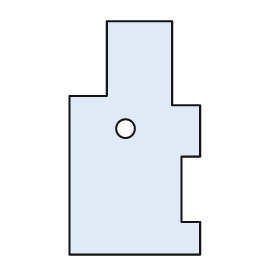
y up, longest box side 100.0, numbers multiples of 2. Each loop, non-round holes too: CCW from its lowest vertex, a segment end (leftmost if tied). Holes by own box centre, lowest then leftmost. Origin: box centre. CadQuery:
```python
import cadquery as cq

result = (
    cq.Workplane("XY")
    .moveTo(-28.0, -50.0)
    .lineTo(28.0, -50.0)
    .lineTo(28.0, -36.0)
    .lineTo(20.0, -36.0)
    .lineTo(20.0, -8.0)
    .lineTo(28.0, -8.0)
    .lineTo(28.0, 14.0)
    .lineTo(16.0, 14.0)
    .lineTo(16.0, 50.0)
    .lineTo(-12.0, 50.0)
    .lineTo(-12.0, 18.0)
    .lineTo(-28.0, 18.0)
    .close()
    .moveTo(-4.0, 4.0)
    .circle(4.0)
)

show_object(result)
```